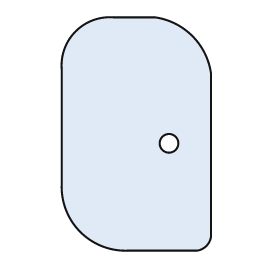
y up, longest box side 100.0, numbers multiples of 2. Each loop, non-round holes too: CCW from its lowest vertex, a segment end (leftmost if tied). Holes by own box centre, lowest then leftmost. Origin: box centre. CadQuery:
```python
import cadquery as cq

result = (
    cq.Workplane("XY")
    .moveTo(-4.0, -50.0)
    .lineTo(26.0, -50.0)
    .threePointArc((30.0, -48.0), (32.0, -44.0))
    .lineTo(32.0, 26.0)
    .threePointArc((24.0, 42.0), (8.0, 50.0))
    .lineTo(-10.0, 50.0)
    .threePointArc((-26.0, 44.0), (-32.0, 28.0))
    .lineTo(-32.0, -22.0)
    .threePointArc((-24.0, -42.0), (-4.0, -50.0))
    .close()
    .moveTo(14.0, -4.0)
    .circle(4.0)
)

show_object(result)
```